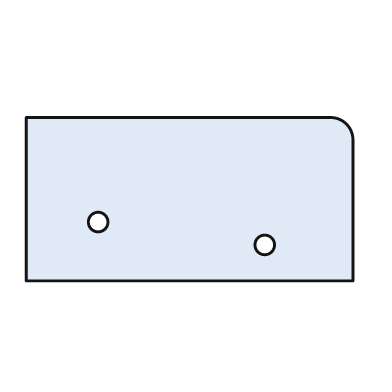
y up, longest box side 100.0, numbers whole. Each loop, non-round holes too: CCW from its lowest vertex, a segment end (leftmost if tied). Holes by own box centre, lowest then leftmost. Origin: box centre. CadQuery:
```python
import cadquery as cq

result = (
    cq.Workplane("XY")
    .moveTo(-50.0, -25.0)
    .lineTo(50.0, -25.0)
    .lineTo(50.0, 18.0)
    .threePointArc((48.0, 23.0), (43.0, 25.0))
    .lineTo(-50.0, 25.0)
    .close()
    .moveTo(23.0, -14.0)
    .circle(3.0)
    .moveTo(-28.0, -7.0)
    .circle(3.0)
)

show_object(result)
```